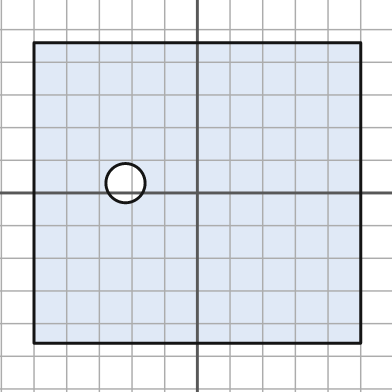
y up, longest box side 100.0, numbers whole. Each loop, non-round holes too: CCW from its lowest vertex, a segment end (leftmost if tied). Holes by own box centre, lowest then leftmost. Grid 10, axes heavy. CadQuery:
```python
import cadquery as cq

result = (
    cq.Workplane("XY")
    .moveTo(-50.0, -46.0)
    .lineTo(50.0, -46.0)
    .lineTo(50.0, 46.0)
    .lineTo(-50.0, 46.0)
    .close()
    .moveTo(-22.0, 3.0)
    .circle(6.0)
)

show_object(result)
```